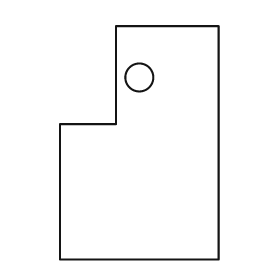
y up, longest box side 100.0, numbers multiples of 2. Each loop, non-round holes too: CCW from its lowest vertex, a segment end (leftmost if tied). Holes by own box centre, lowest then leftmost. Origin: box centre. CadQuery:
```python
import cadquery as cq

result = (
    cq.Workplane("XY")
    .moveTo(-34.0, -50.0)
    .lineTo(34.0, -50.0)
    .lineTo(34.0, 50.0)
    .lineTo(-10.0, 50.0)
    .lineTo(-10.0, 8.0)
    .lineTo(-34.0, 8.0)
    .close()
    .moveTo(0.0, 28.0)
    .circle(6.0)
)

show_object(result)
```